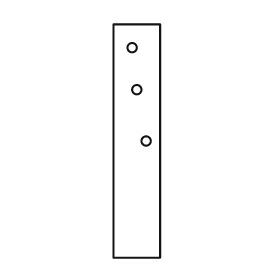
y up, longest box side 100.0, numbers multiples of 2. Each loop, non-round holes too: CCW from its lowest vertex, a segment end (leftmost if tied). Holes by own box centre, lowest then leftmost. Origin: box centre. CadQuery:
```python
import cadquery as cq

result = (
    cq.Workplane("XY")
    .moveTo(-10.0, -50.0)
    .lineTo(10.0, -50.0)
    .lineTo(10.0, 50.0)
    .lineTo(-10.0, 50.0)
    .close()
    .moveTo(4.0, 0.0)
    .circle(2.0)
    .moveTo(0.0, 22.0)
    .circle(2.0)
    .moveTo(-2.0, 40.0)
    .circle(2.0)
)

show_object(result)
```